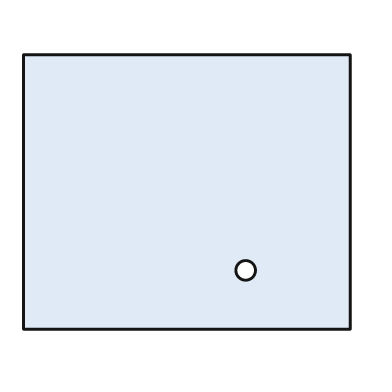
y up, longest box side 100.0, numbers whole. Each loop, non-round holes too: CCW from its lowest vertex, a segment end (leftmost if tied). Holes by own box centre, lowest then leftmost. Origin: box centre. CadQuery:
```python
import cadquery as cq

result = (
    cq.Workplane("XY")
    .moveTo(-50.0, -42.0)
    .lineTo(50.0, -42.0)
    .lineTo(50.0, 42.0)
    .lineTo(-50.0, 42.0)
    .close()
    .moveTo(18.0, -24.0)
    .circle(3.0)
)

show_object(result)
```